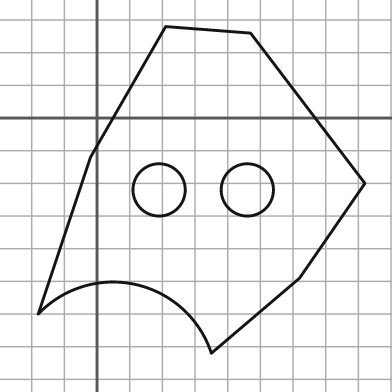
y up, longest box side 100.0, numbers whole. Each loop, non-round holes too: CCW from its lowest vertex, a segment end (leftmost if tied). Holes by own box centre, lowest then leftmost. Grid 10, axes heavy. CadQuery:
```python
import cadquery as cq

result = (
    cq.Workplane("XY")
    .moveTo(35.0, -72.0)
    .lineTo(62.0, -49.0)
    .lineTo(82.0, -20.0)
    .lineTo(47.0, 26.0)
    .lineTo(21.0, 28.0)
    .lineTo(-2.0, -12.0)
    .lineTo(-18.0, -60.0)
    .threePointArc((12.0, -51.0), (35.0, -72.0))
    .close()
    .moveTo(19.0, -22.0)
    .circle(8.0)
    .moveTo(46.0, -22.0)
    .circle(8.0)
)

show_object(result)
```